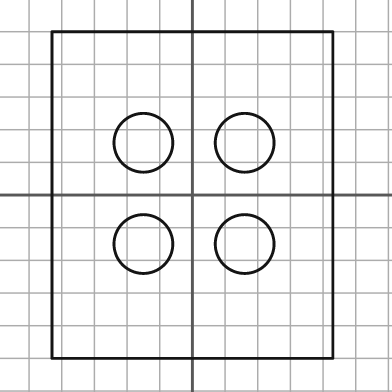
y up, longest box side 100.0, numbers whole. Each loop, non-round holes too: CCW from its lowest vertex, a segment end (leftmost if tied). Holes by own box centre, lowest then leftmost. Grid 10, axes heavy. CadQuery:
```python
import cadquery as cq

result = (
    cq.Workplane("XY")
    .moveTo(-43.0, -50.0)
    .lineTo(43.0, -50.0)
    .lineTo(43.0, 50.0)
    .lineTo(-43.0, 50.0)
    .close()
    .moveTo(-15.0, -15.0)
    .circle(9.0)
    .moveTo(16.0, -15.0)
    .circle(9.0)
    .moveTo(-15.0, 16.0)
    .circle(9.0)
    .moveTo(16.0, 16.0)
    .circle(9.0)
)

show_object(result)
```